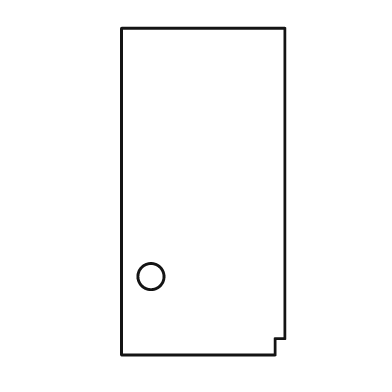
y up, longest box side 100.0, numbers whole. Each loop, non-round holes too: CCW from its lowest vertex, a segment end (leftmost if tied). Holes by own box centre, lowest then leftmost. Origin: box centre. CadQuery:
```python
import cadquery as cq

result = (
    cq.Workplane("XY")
    .moveTo(-25.0, -50.0)
    .lineTo(22.0, -50.0)
    .lineTo(22.0, -45.0)
    .lineTo(25.0, -45.0)
    .lineTo(25.0, 50.0)
    .lineTo(-25.0, 50.0)
    .close()
    .moveTo(-16.0, -26.0)
    .circle(4.0)
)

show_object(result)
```